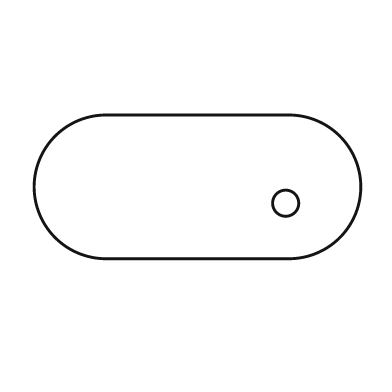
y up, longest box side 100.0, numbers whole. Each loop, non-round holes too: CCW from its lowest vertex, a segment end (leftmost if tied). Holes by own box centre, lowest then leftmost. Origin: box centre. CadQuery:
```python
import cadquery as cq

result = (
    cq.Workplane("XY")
    .moveTo(-28.0, -22.0)
    .lineTo(28.0, -22.0)
    .threePointArc((50.0, 0.0), (28.0, 22.0))
    .lineTo(-28.0, 22.0)
    .threePointArc((-50.0, 0.0), (-28.0, -22.0))
    .close()
    .moveTo(27.0, -5.0)
    .circle(4.0)
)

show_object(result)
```